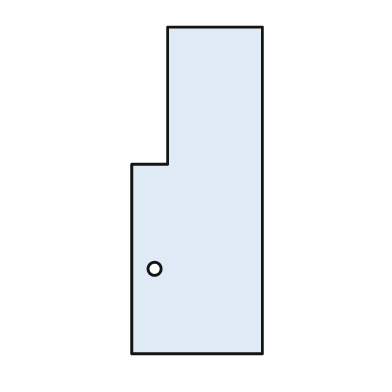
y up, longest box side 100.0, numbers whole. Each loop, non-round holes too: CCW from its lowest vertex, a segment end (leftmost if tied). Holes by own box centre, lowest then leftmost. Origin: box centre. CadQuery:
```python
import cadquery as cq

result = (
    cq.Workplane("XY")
    .moveTo(-20.0, -50.0)
    .lineTo(20.0, -50.0)
    .lineTo(20.0, 50.0)
    .lineTo(-9.0, 50.0)
    .lineTo(-9.0, 8.0)
    .lineTo(-20.0, 8.0)
    .close()
    .moveTo(-13.0, -24.0)
    .circle(2.0)
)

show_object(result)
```